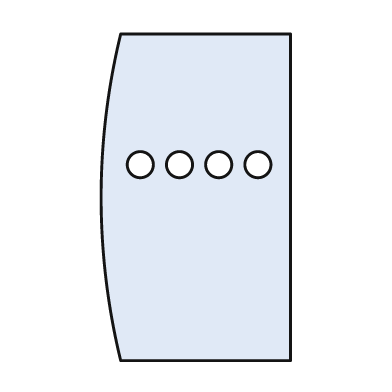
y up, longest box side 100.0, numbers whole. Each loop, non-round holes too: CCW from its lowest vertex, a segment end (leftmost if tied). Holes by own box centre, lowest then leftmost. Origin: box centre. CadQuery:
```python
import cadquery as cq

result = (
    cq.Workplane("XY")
    .moveTo(-23.0, -50.0)
    .lineTo(29.0, -50.0)
    .lineTo(29.0, 50.0)
    .lineTo(-23.0, 50.0)
    .threePointArc((-29.0, 0.0), (-23.0, -50.0))
    .close()
    .moveTo(-17.0, 10.0)
    .circle(4.0)
    .moveTo(-5.0, 10.0)
    .circle(4.0)
    .moveTo(7.0, 10.0)
    .circle(4.0)
    .moveTo(19.0, 10.0)
    .circle(4.0)
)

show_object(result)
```